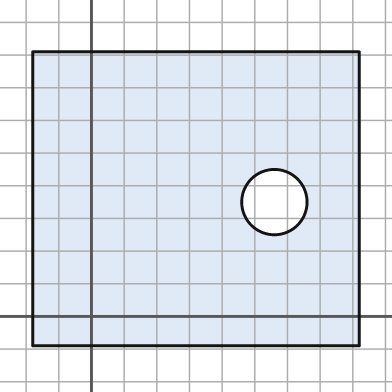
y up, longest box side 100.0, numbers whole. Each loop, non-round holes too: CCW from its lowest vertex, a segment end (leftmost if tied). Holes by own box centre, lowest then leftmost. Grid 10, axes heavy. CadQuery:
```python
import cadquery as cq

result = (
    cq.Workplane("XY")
    .moveTo(-18.0, -9.0)
    .lineTo(82.0, -9.0)
    .lineTo(82.0, 81.0)
    .lineTo(-18.0, 81.0)
    .close()
    .moveTo(56.0, 35.0)
    .circle(10.0)
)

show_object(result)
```